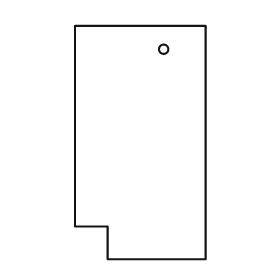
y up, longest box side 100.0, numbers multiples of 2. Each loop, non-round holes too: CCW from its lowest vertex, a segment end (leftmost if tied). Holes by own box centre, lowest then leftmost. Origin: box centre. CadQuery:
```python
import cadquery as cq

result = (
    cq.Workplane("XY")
    .moveTo(-14.0, -50.0)
    .lineTo(28.0, -50.0)
    .lineTo(28.0, 50.0)
    .lineTo(-28.0, 50.0)
    .lineTo(-28.0, -36.0)
    .lineTo(-14.0, -36.0)
    .close()
    .moveTo(10.0, 40.0)
    .circle(2.0)
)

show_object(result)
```